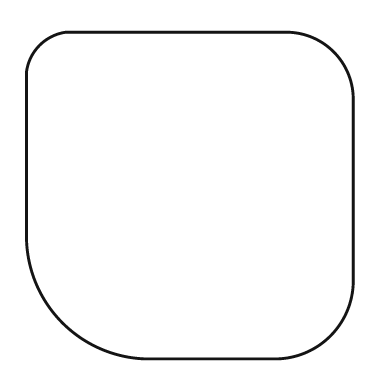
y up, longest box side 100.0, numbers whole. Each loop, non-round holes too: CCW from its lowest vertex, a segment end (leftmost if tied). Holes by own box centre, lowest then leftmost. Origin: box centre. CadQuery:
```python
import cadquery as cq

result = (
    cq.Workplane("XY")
    .moveTo(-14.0, -50.0)
    .lineTo(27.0, -50.0)
    .threePointArc((43.0, -43.0), (50.0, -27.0))
    .lineTo(50.0, 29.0)
    .threePointArc((44.0, 44.0), (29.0, 50.0))
    .lineTo(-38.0, 50.0)
    .threePointArc((-46.0, 46.0), (-50.0, 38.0))
    .lineTo(-50.0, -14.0)
    .threePointArc((-39.0, -39.0), (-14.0, -50.0))
    .close()
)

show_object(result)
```